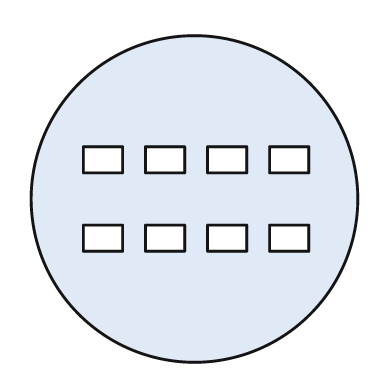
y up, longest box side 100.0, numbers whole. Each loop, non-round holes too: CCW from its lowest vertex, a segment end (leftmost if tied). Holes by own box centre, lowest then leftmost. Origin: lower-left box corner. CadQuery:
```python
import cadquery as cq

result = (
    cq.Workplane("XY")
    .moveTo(50.0, 50.0)
    .circle(50.0)
    .moveTo(16.0, 34.0)
    .lineTo(28.0, 34.0)
    .lineTo(28.0, 42.0)
    .lineTo(16.0, 42.0)
    .close()
    .moveTo(35.0, 34.0)
    .lineTo(47.0, 34.0)
    .lineTo(47.0, 42.0)
    .lineTo(35.0, 42.0)
    .close()
    .moveTo(54.0, 34.0)
    .lineTo(66.0, 34.0)
    .lineTo(66.0, 42.0)
    .lineTo(54.0, 42.0)
    .close()
    .moveTo(73.0, 34.0)
    .lineTo(85.0, 34.0)
    .lineTo(85.0, 42.0)
    .lineTo(73.0, 42.0)
    .close()
    .moveTo(16.0, 58.0)
    .lineTo(28.0, 58.0)
    .lineTo(28.0, 66.0)
    .lineTo(16.0, 66.0)
    .close()
    .moveTo(35.0, 58.0)
    .lineTo(47.0, 58.0)
    .lineTo(47.0, 66.0)
    .lineTo(35.0, 66.0)
    .close()
    .moveTo(54.0, 58.0)
    .lineTo(66.0, 58.0)
    .lineTo(66.0, 66.0)
    .lineTo(54.0, 66.0)
    .close()
    .moveTo(73.0, 58.0)
    .lineTo(85.0, 58.0)
    .lineTo(85.0, 66.0)
    .lineTo(73.0, 66.0)
    .close()
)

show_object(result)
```